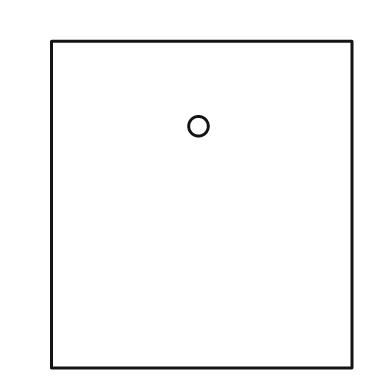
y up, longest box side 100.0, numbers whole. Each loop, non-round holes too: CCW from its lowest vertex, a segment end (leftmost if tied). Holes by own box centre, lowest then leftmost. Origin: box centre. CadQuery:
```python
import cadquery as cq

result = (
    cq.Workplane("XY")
    .moveTo(-46.0, -50.0)
    .lineTo(46.0, -50.0)
    .lineTo(46.0, 50.0)
    .lineTo(-46.0, 50.0)
    .close()
    .moveTo(-1.0, 24.0)
    .circle(3.0)
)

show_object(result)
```